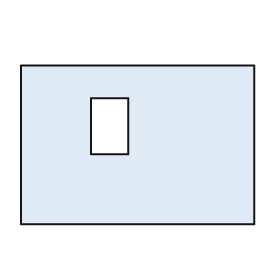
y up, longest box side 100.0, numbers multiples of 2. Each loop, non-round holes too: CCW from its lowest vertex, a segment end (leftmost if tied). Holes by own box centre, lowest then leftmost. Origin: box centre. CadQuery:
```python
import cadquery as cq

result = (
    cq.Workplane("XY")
    .moveTo(-50.0, -34.0)
    .lineTo(50.0, -34.0)
    .lineTo(50.0, 34.0)
    .lineTo(-50.0, 34.0)
    .close()
    .moveTo(-20.0, -4.0)
    .lineTo(-4.0, -4.0)
    .lineTo(-4.0, 20.0)
    .lineTo(-20.0, 20.0)
    .close()
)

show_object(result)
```